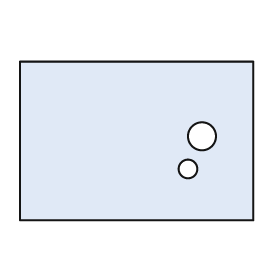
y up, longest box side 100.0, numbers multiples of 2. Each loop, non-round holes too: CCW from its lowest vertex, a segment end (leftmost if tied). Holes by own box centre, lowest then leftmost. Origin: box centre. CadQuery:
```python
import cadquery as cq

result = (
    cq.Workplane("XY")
    .moveTo(-50.0, -34.0)
    .lineTo(50.0, -34.0)
    .lineTo(50.0, 34.0)
    .lineTo(-50.0, 34.0)
    .close()
    .moveTo(22.0, -12.0)
    .circle(4.0)
    .moveTo(28.0, 2.0)
    .circle(6.0)
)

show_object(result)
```